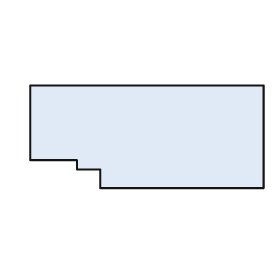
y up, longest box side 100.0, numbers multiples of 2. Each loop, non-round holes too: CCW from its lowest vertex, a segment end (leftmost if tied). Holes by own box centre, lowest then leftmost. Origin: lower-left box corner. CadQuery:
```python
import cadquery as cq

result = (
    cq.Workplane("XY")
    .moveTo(30.0, 0.0)
    .lineTo(100.0, 0.0)
    .lineTo(100.0, 44.0)
    .lineTo(0.0, 44.0)
    .lineTo(0.0, 12.0)
    .lineTo(20.0, 12.0)
    .lineTo(20.0, 8.0)
    .lineTo(30.0, 8.0)
    .close()
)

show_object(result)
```